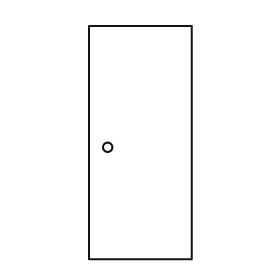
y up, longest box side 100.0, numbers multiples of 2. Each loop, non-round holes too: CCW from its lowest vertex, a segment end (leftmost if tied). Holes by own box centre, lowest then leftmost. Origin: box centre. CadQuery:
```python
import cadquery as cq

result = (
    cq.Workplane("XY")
    .moveTo(-22.0, -50.0)
    .lineTo(22.0, -50.0)
    .lineTo(22.0, 50.0)
    .lineTo(-22.0, 50.0)
    .close()
    .moveTo(-14.0, -2.0)
    .circle(2.0)
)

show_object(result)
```